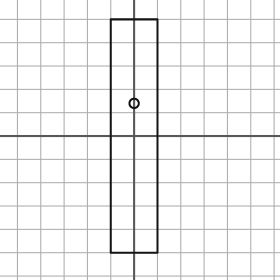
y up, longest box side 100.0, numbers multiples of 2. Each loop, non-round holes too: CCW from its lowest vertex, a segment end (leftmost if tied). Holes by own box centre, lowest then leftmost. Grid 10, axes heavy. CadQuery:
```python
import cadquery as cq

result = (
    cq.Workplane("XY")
    .moveTo(-10.0, -50.0)
    .lineTo(10.0, -50.0)
    .lineTo(10.0, 50.0)
    .lineTo(-10.0, 50.0)
    .close()
    .moveTo(0.0, 14.0)
    .circle(2.0)
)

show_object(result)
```